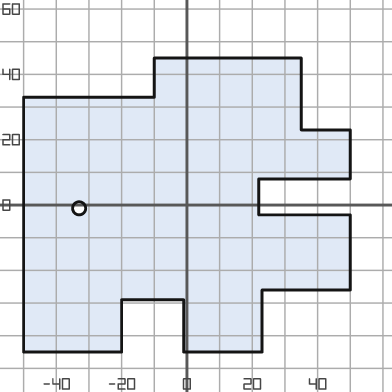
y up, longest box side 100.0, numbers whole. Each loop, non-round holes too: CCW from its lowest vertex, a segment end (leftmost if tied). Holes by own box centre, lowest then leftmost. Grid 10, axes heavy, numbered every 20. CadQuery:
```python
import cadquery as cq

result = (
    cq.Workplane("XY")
    .moveTo(-50.0, -45.0)
    .lineTo(-20.0, -45.0)
    .lineTo(-20.0, -29.0)
    .lineTo(-1.0, -29.0)
    .lineTo(-1.0, -45.0)
    .lineTo(23.0, -45.0)
    .lineTo(23.0, -26.0)
    .lineTo(50.0, -26.0)
    .lineTo(50.0, -3.0)
    .lineTo(22.0, -3.0)
    .lineTo(22.0, 8.0)
    .lineTo(50.0, 8.0)
    .lineTo(50.0, 23.0)
    .lineTo(35.0, 23.0)
    .lineTo(35.0, 45.0)
    .lineTo(-10.0, 45.0)
    .lineTo(-10.0, 33.0)
    .lineTo(-50.0, 33.0)
    .close()
    .moveTo(-33.0, -1.0)
    .circle(2.0)
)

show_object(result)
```